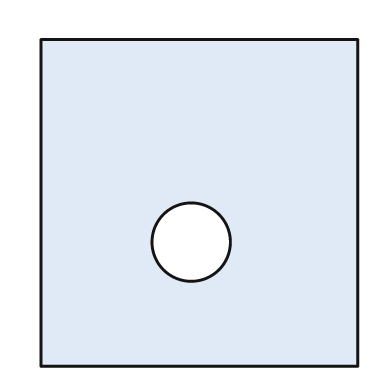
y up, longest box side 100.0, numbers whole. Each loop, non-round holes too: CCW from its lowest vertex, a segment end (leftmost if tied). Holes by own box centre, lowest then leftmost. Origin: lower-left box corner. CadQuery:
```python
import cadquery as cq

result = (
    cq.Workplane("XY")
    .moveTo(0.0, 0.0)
    .lineTo(97.0, 0.0)
    .lineTo(97.0, 100.0)
    .lineTo(0.0, 100.0)
    .close()
    .moveTo(46.0, 38.0)
    .circle(12.0)
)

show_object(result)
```